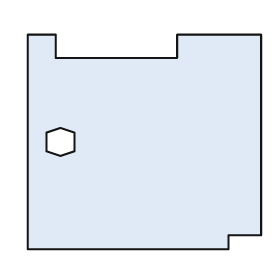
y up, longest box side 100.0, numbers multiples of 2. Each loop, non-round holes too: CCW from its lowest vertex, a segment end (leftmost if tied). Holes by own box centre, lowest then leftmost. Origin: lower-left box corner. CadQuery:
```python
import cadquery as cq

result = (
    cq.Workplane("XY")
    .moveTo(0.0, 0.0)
    .lineTo(86.0, 0.0)
    .lineTo(86.0, 6.0)
    .lineTo(100.0, 6.0)
    .lineTo(100.0, 92.0)
    .lineTo(64.0, 92.0)
    .lineTo(64.0, 82.0)
    .lineTo(12.0, 82.0)
    .lineTo(12.0, 92.0)
    .lineTo(0.0, 92.0)
    .close()
    .moveTo(14.0, 40.0)
    .lineTo(20.0, 42.0)
    .lineTo(20.0, 50.0)
    .lineTo(14.0, 52.0)
    .lineTo(8.0, 50.0)
    .lineTo(8.0, 42.0)
    .close()
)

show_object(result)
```